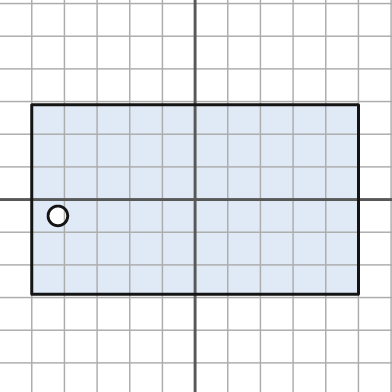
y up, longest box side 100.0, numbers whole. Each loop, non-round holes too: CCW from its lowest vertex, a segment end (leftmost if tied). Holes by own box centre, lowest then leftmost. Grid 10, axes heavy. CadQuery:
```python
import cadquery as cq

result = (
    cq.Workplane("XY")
    .moveTo(-50.0, -29.0)
    .lineTo(50.0, -29.0)
    .lineTo(50.0, 29.0)
    .lineTo(-50.0, 29.0)
    .close()
    .moveTo(-42.0, -5.0)
    .circle(3.0)
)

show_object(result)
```